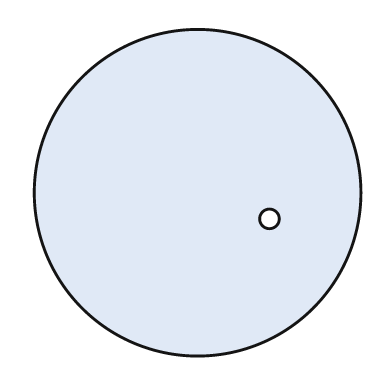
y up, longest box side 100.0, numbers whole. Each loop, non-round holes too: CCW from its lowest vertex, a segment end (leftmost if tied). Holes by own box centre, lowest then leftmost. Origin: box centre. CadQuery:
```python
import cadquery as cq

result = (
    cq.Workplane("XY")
    .moveTo(0.0, 0.0)
    .circle(50.0)
    .moveTo(22.0, -8.0)
    .circle(3.0)
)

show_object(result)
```